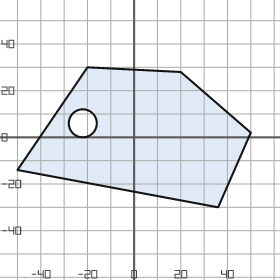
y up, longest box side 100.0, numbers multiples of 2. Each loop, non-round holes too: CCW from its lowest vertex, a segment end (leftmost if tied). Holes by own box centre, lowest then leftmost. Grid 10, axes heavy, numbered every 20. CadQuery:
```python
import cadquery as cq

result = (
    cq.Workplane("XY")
    .moveTo(36.0, -30.0)
    .lineTo(50.0, 2.0)
    .lineTo(20.0, 28.0)
    .lineTo(-20.0, 30.0)
    .lineTo(-50.0, -14.0)
    .close()
    .moveTo(-22.0, 6.0)
    .circle(6.0)
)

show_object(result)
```